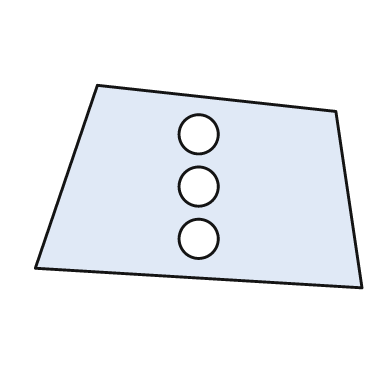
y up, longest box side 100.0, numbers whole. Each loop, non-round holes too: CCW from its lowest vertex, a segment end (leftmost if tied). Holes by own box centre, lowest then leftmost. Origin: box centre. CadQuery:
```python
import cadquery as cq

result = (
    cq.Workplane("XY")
    .moveTo(50.0, -31.0)
    .lineTo(42.0, 23.0)
    .lineTo(-31.0, 31.0)
    .lineTo(-50.0, -25.0)
    .close()
    .moveTo(0.0, -16.0)
    .circle(6.0)
    .moveTo(0.0, 0.0)
    .circle(6.0)
    .moveTo(0.0, 16.0)
    .circle(6.0)
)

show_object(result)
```